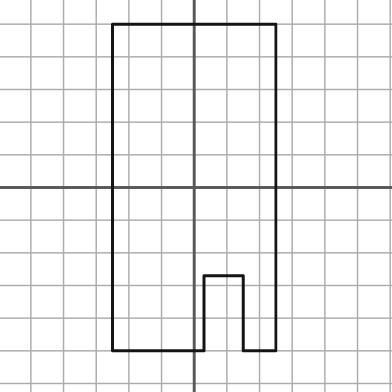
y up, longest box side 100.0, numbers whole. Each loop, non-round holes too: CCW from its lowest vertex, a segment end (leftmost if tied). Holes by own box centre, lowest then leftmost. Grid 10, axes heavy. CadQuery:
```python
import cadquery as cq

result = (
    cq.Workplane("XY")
    .moveTo(-25.0, -50.0)
    .lineTo(3.0, -50.0)
    .lineTo(3.0, -27.0)
    .lineTo(15.0, -27.0)
    .lineTo(15.0, -50.0)
    .lineTo(25.0, -50.0)
    .lineTo(25.0, 50.0)
    .lineTo(-25.0, 50.0)
    .close()
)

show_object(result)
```